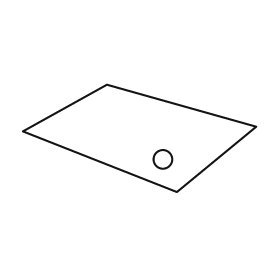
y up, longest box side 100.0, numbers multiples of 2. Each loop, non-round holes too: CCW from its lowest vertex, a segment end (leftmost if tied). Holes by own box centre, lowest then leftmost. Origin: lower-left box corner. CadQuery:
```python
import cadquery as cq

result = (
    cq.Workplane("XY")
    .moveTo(66.0, 0.0)
    .lineTo(100.0, 28.0)
    .lineTo(36.0, 46.0)
    .lineTo(0.0, 26.0)
    .close()
    .moveTo(60.0, 14.0)
    .circle(4.0)
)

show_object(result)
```